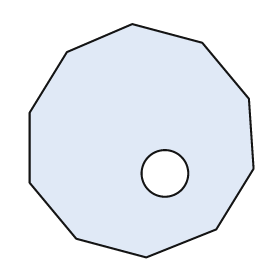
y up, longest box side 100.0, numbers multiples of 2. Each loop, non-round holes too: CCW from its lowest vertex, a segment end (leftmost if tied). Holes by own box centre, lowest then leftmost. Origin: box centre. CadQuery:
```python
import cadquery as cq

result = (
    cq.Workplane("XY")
    .moveTo(2.0, -50.0)
    .lineTo(32.0, -38.0)
    .lineTo(48.0, -12.0)
    .lineTo(46.0, 18.0)
    .lineTo(26.0, 42.0)
    .lineTo(-4.0, 50.0)
    .lineTo(-32.0, 38.0)
    .lineTo(-48.0, 12.0)
    .lineTo(-48.0, -18.0)
    .lineTo(-28.0, -42.0)
    .close()
    .moveTo(10.0, -14.0)
    .circle(10.0)
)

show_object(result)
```